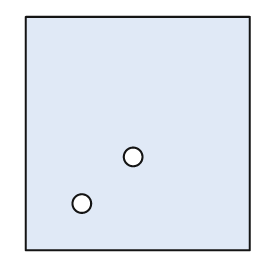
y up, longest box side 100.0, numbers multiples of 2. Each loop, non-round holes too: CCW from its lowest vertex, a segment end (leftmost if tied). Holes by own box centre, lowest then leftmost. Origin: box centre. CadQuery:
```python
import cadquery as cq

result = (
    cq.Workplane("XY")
    .moveTo(-48.0, -50.0)
    .lineTo(48.0, -50.0)
    .lineTo(48.0, 50.0)
    .lineTo(-48.0, 50.0)
    .close()
    .moveTo(-24.0, -30.0)
    .circle(4.0)
    .moveTo(-2.0, -10.0)
    .circle(4.0)
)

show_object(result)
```